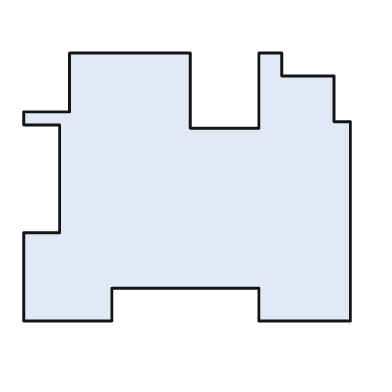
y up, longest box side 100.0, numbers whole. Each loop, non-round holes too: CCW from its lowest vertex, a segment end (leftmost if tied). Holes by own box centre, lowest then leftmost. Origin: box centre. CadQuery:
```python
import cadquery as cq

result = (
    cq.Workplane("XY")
    .moveTo(-50.0, -41.0)
    .lineTo(-23.0, -41.0)
    .lineTo(-23.0, -31.0)
    .lineTo(22.0, -31.0)
    .lineTo(22.0, -41.0)
    .lineTo(50.0, -41.0)
    .lineTo(50.0, 20.0)
    .lineTo(45.0, 20.0)
    .lineTo(45.0, 34.0)
    .lineTo(29.0, 34.0)
    .lineTo(29.0, 41.0)
    .lineTo(22.0, 41.0)
    .lineTo(22.0, 18.0)
    .lineTo(1.0, 18.0)
    .lineTo(1.0, 41.0)
    .lineTo(-36.0, 41.0)
    .lineTo(-36.0, 23.0)
    .lineTo(-50.0, 23.0)
    .lineTo(-50.0, 19.0)
    .lineTo(-39.0, 19.0)
    .lineTo(-39.0, -14.0)
    .lineTo(-50.0, -14.0)
    .close()
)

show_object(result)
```